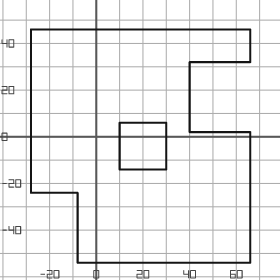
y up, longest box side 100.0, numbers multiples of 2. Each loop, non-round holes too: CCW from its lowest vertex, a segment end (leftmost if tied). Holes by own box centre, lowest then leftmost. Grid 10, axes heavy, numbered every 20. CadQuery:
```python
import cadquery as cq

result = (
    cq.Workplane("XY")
    .moveTo(-8.0, -54.0)
    .lineTo(66.0, -54.0)
    .lineTo(66.0, 2.0)
    .lineTo(40.0, 2.0)
    .lineTo(40.0, 32.0)
    .lineTo(66.0, 32.0)
    .lineTo(66.0, 46.0)
    .lineTo(-28.0, 46.0)
    .lineTo(-28.0, -24.0)
    .lineTo(-8.0, -24.0)
    .close()
    .moveTo(10.0, -14.0)
    .lineTo(30.0, -14.0)
    .lineTo(30.0, 6.0)
    .lineTo(10.0, 6.0)
    .close()
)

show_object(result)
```